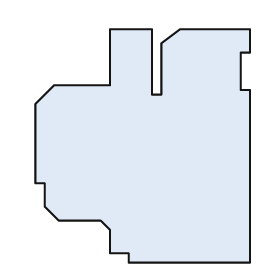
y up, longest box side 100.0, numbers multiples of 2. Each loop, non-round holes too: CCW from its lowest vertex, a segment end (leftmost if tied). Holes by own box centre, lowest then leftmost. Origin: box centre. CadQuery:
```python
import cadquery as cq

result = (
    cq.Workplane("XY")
    .moveTo(-6.0, -50.0)
    .lineTo(46.0, -50.0)
    .lineTo(46.0, 24.0)
    .lineTo(42.0, 24.0)
    .lineTo(42.0, 40.0)
    .lineTo(46.0, 40.0)
    .lineTo(46.0, 50.0)
    .lineTo(16.0, 50.0)
    .lineTo(8.0, 44.0)
    .lineTo(8.0, 22.0)
    .lineTo(4.0, 22.0)
    .lineTo(4.0, 50.0)
    .lineTo(-14.0, 50.0)
    .lineTo(-14.0, 26.0)
    .lineTo(-38.0, 26.0)
    .lineTo(-46.0, 18.0)
    .lineTo(-46.0, -16.0)
    .lineTo(-42.0, -16.0)
    .lineTo(-42.0, -26.0)
    .lineTo(-36.0, -32.0)
    .lineTo(-18.0, -32.0)
    .lineTo(-14.0, -36.0)
    .lineTo(-14.0, -46.0)
    .lineTo(-6.0, -46.0)
    .close()
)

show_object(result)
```